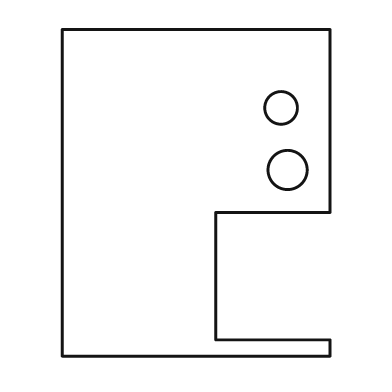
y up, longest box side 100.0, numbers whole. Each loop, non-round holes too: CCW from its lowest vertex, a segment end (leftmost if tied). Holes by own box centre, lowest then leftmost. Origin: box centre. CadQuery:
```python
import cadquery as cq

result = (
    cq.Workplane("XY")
    .moveTo(-41.0, -50.0)
    .lineTo(41.0, -50.0)
    .lineTo(41.0, -45.0)
    .lineTo(6.0, -45.0)
    .lineTo(6.0, -6.0)
    .lineTo(41.0, -6.0)
    .lineTo(41.0, 50.0)
    .lineTo(-41.0, 50.0)
    .close()
    .moveTo(28.0, 7.0)
    .circle(6.0)
    .moveTo(26.0, 26.0)
    .circle(5.0)
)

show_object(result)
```